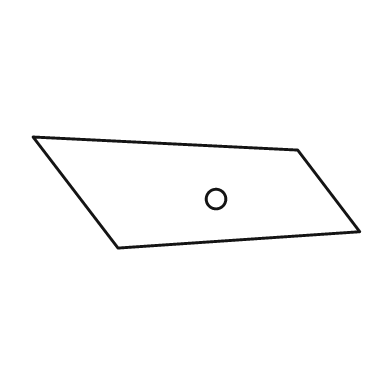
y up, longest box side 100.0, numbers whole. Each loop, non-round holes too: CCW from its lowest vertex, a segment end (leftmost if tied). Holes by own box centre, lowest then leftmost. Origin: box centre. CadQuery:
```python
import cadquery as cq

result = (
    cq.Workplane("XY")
    .moveTo(-24.0, -17.0)
    .lineTo(50.0, -12.0)
    .lineTo(31.0, 13.0)
    .lineTo(-50.0, 17.0)
    .close()
    .moveTo(6.0, -2.0)
    .circle(3.0)
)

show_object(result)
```